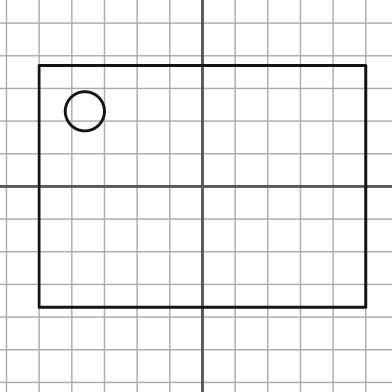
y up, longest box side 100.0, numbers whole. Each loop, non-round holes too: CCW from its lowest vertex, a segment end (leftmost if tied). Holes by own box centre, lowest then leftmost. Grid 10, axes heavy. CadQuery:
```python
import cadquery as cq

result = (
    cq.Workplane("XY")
    .moveTo(-50.0, -37.0)
    .lineTo(50.0, -37.0)
    .lineTo(50.0, 37.0)
    .lineTo(-50.0, 37.0)
    .close()
    .moveTo(-36.0, 23.0)
    .circle(6.0)
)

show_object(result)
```